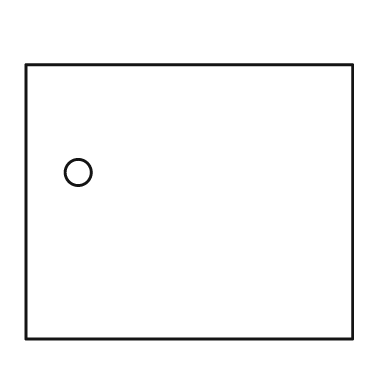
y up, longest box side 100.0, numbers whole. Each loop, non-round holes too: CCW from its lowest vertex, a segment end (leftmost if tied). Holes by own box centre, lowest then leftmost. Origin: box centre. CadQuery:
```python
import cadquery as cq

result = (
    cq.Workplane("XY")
    .moveTo(-50.0, -42.0)
    .lineTo(50.0, -42.0)
    .lineTo(50.0, 42.0)
    .lineTo(-50.0, 42.0)
    .close()
    .moveTo(-34.0, 9.0)
    .circle(4.0)
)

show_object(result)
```